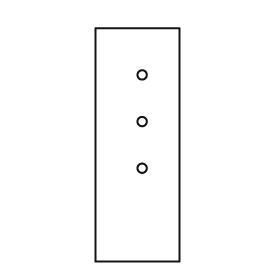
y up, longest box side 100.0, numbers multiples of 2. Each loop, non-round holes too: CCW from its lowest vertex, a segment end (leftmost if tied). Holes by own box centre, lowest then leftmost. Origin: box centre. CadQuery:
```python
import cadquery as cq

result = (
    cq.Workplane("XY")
    .moveTo(-18.0, -50.0)
    .lineTo(18.0, -50.0)
    .lineTo(18.0, 50.0)
    .lineTo(-18.0, 50.0)
    .close()
    .moveTo(2.0, -10.0)
    .circle(2.0)
    .moveTo(2.0, 10.0)
    .circle(2.0)
    .moveTo(2.0, 30.0)
    .circle(2.0)
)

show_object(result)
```